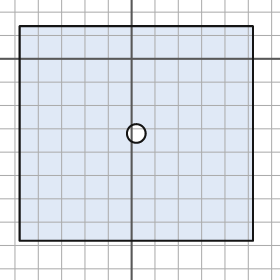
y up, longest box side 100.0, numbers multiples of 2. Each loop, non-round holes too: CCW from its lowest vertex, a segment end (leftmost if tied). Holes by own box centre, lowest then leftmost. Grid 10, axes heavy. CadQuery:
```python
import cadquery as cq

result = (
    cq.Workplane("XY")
    .moveTo(-48.0, -78.0)
    .lineTo(52.0, -78.0)
    .lineTo(52.0, 14.0)
    .lineTo(-48.0, 14.0)
    .close()
    .moveTo(2.0, -32.0)
    .circle(4.0)
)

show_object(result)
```